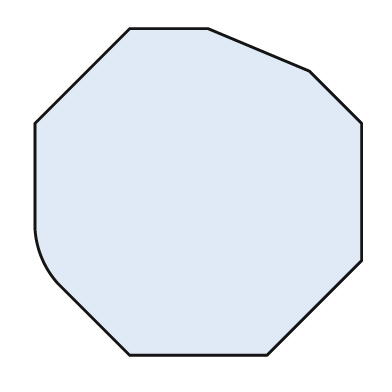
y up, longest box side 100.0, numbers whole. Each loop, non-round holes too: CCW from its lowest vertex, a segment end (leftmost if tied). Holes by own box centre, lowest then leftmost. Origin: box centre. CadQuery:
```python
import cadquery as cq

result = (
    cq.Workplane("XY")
    .moveTo(-21.0, -50.0)
    .lineTo(21.0, -50.0)
    .lineTo(50.0, -21.0)
    .lineTo(50.0, 21.0)
    .lineTo(34.0, 37.0)
    .lineTo(3.0, 50.0)
    .lineTo(-21.0, 50.0)
    .lineTo(-50.0, 21.0)
    .lineTo(-50.0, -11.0)
    .threePointArc((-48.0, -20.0), (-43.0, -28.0))
    .close()
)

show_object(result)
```